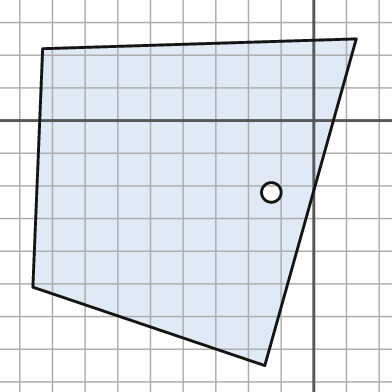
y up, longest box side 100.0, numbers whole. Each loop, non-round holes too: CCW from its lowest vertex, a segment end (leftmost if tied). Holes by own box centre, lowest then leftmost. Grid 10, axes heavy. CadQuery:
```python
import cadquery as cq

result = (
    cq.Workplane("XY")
    .moveTo(-15.0, -75.0)
    .lineTo(13.0, 25.0)
    .lineTo(-83.0, 22.0)
    .lineTo(-86.0, -51.0)
    .close()
    .moveTo(-13.0, -22.0)
    .circle(3.0)
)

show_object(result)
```